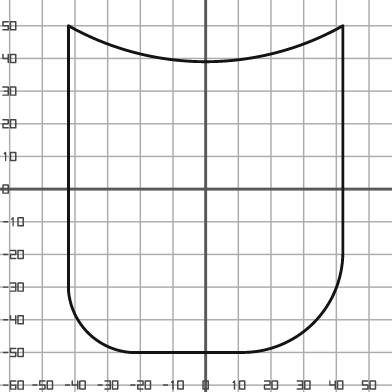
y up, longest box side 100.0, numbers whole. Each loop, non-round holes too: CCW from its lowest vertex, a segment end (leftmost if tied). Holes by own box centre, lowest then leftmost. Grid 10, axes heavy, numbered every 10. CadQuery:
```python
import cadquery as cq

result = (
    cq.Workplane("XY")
    .moveTo(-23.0, -50.0)
    .lineTo(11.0, -50.0)
    .threePointArc((33.0, -41.0), (42.0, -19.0))
    .lineTo(42.0, 50.0)
    .threePointArc((0.0, 39.0), (-42.0, 50.0))
    .lineTo(-42.0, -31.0)
    .threePointArc((-36.0, -44.0), (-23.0, -50.0))
    .close()
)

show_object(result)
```